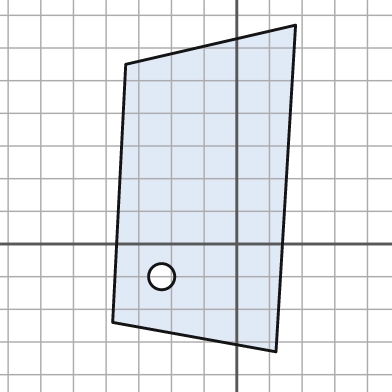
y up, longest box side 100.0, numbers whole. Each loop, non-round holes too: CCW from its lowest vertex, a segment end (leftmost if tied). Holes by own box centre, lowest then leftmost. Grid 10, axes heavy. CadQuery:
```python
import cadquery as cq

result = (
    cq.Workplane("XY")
    .moveTo(12.0, -33.0)
    .lineTo(18.0, 67.0)
    .lineTo(-34.0, 55.0)
    .lineTo(-38.0, -24.0)
    .close()
    .moveTo(-23.0, -10.0)
    .circle(4.0)
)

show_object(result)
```